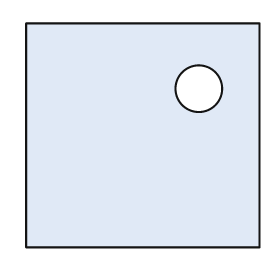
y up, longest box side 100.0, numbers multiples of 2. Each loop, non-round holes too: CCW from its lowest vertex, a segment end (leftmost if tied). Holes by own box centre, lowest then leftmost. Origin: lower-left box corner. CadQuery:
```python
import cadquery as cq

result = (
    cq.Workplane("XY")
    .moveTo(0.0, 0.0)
    .lineTo(100.0, 0.0)
    .lineTo(100.0, 96.0)
    .lineTo(0.0, 96.0)
    .close()
    .moveTo(74.0, 68.0)
    .circle(10.0)
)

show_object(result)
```